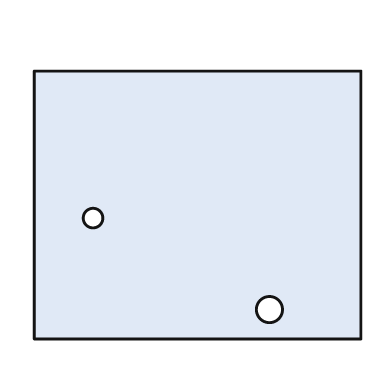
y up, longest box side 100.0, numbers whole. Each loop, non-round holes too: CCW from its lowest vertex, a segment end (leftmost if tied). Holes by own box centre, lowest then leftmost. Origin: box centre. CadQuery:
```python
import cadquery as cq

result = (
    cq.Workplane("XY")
    .moveTo(-50.0, -41.0)
    .lineTo(50.0, -41.0)
    .lineTo(50.0, 41.0)
    .lineTo(-50.0, 41.0)
    .close()
    .moveTo(22.0, -32.0)
    .circle(4.0)
    .moveTo(-32.0, -4.0)
    .circle(3.0)
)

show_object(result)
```